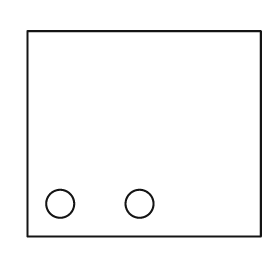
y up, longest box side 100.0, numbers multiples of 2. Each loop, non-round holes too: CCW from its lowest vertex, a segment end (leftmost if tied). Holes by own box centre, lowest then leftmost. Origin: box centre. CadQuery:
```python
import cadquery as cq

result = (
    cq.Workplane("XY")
    .moveTo(-50.0, -44.0)
    .lineTo(50.0, -44.0)
    .lineTo(50.0, 44.0)
    .lineTo(-50.0, 44.0)
    .close()
    .moveTo(-36.0, -30.0)
    .circle(6.0)
    .moveTo(-2.0, -30.0)
    .circle(6.0)
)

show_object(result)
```